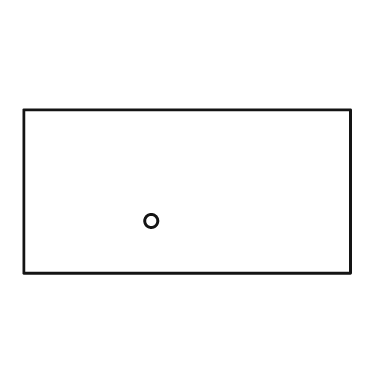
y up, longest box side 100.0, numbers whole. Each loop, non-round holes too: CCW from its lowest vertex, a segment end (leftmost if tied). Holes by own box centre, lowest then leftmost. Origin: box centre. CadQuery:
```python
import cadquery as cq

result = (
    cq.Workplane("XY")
    .moveTo(-50.0, -25.0)
    .lineTo(50.0, -25.0)
    .lineTo(50.0, 25.0)
    .lineTo(-50.0, 25.0)
    .close()
    .moveTo(-11.0, -9.0)
    .circle(2.0)
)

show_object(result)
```